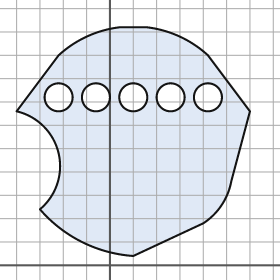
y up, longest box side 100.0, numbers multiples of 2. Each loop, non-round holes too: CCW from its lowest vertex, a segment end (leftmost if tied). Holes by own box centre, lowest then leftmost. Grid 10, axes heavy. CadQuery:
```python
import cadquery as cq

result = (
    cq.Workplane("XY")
    .moveTo(10.0, 4.0)
    .lineTo(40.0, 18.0)
    .threePointArc((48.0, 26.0), (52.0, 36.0))
    .lineTo(60.0, 66.0)
    .lineTo(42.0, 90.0)
    .threePointArc((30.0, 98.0), (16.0, 102.0))
    .lineTo(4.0, 102.0)
    .threePointArc((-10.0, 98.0), (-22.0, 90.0))
    .lineTo(-40.0, 66.0)
    .threePointArc((-22.0, 48.0), (-30.0, 24.0))
    .threePointArc((-12.0, 10.0), (10.0, 4.0))
    .close()
    .moveTo(-22.0, 72.0)
    .circle(6.0)
    .moveTo(-6.0, 72.0)
    .circle(6.0)
    .moveTo(10.0, 72.0)
    .circle(6.0)
    .moveTo(26.0, 72.0)
    .circle(6.0)
    .moveTo(42.0, 72.0)
    .circle(6.0)
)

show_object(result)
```